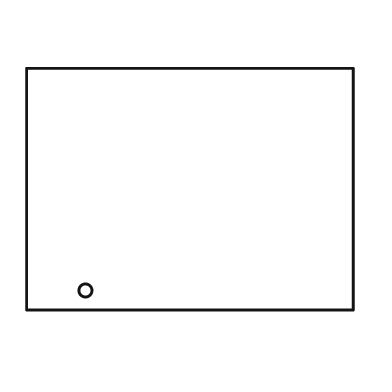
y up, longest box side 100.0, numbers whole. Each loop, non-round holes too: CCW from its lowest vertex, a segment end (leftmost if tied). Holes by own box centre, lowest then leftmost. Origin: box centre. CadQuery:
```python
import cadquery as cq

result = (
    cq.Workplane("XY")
    .moveTo(-50.0, -37.0)
    .lineTo(50.0, -37.0)
    .lineTo(50.0, 37.0)
    .lineTo(-50.0, 37.0)
    .close()
    .moveTo(-32.0, -31.0)
    .circle(2.0)
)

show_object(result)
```